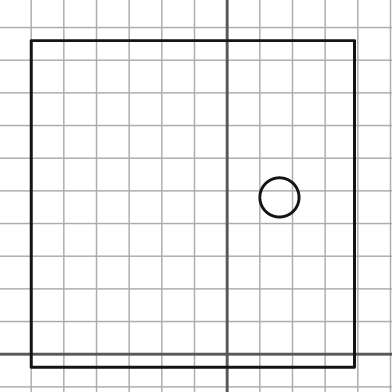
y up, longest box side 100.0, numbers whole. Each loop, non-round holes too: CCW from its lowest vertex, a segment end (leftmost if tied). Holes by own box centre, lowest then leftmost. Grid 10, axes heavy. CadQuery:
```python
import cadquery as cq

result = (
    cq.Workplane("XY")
    .moveTo(-60.0, -4.0)
    .lineTo(39.0, -4.0)
    .lineTo(39.0, 96.0)
    .lineTo(-60.0, 96.0)
    .close()
    .moveTo(16.0, 48.0)
    .circle(6.0)
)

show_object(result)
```